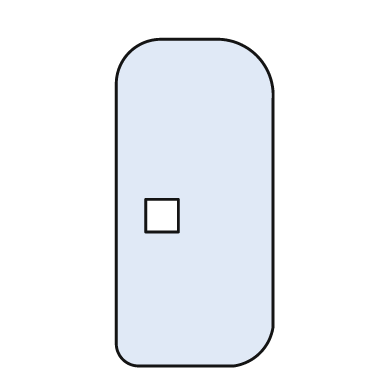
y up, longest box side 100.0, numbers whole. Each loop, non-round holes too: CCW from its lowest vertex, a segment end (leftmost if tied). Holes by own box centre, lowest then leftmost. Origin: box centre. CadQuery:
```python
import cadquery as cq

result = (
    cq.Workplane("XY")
    .moveTo(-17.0, -50.0)
    .lineTo(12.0, -50.0)
    .threePointArc((20.0, -46.0), (24.0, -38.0))
    .lineTo(24.0, 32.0)
    .threePointArc((19.0, 45.0), (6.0, 50.0))
    .lineTo(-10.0, 50.0)
    .threePointArc((-20.0, 46.0), (-24.0, 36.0))
    .lineTo(-24.0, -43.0)
    .threePointArc((-22.0, -48.0), (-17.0, -50.0))
    .close()
    .moveTo(-15.0, -9.0)
    .lineTo(-5.0, -9.0)
    .lineTo(-5.0, 1.0)
    .lineTo(-15.0, 1.0)
    .close()
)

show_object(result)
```